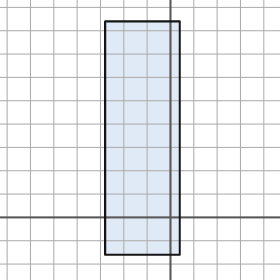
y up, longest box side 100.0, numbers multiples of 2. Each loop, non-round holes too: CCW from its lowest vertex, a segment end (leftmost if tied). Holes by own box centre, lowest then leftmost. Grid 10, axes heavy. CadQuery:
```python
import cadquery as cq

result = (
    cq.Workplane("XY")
    .moveTo(-28.0, -16.0)
    .lineTo(4.0, -16.0)
    .lineTo(4.0, 84.0)
    .lineTo(-28.0, 84.0)
    .close()
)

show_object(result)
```